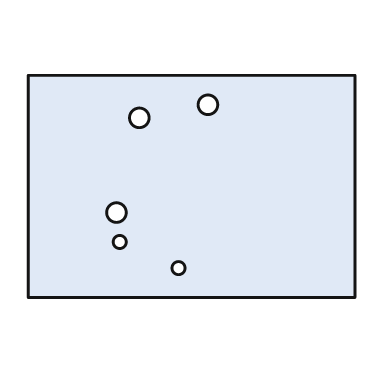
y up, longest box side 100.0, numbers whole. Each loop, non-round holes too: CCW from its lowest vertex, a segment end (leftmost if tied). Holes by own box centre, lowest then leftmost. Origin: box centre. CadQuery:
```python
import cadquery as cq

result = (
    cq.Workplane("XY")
    .moveTo(-50.0, -34.0)
    .lineTo(50.0, -34.0)
    .lineTo(50.0, 34.0)
    .lineTo(-50.0, 34.0)
    .close()
    .moveTo(-4.0, -25.0)
    .circle(2.0)
    .moveTo(-22.0, -17.0)
    .circle(2.0)
    .moveTo(-23.0, -8.0)
    .circle(3.0)
    .moveTo(-16.0, 21.0)
    .circle(3.0)
    .moveTo(5.0, 25.0)
    .circle(3.0)
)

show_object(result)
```